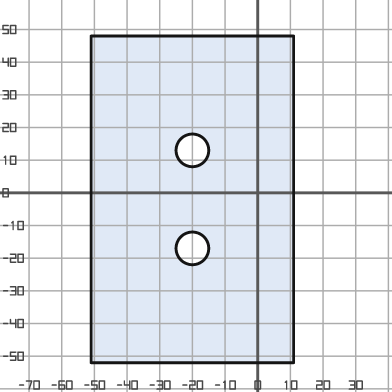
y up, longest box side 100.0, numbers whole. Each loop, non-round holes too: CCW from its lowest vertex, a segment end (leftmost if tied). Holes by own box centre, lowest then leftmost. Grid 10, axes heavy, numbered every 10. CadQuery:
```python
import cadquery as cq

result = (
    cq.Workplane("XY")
    .moveTo(-51.0, -52.0)
    .lineTo(11.0, -52.0)
    .lineTo(11.0, 48.0)
    .lineTo(-51.0, 48.0)
    .close()
    .moveTo(-20.0, -17.0)
    .circle(5.0)
    .moveTo(-20.0, 13.0)
    .circle(5.0)
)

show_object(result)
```